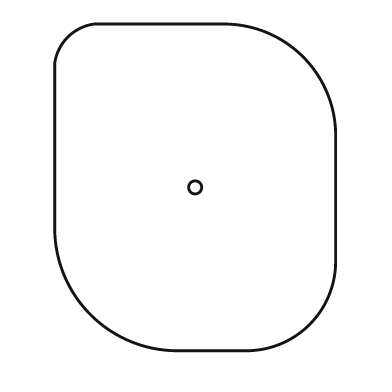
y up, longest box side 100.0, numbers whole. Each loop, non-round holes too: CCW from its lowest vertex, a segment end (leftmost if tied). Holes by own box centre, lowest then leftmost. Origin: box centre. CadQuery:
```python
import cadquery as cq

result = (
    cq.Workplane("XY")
    .moveTo(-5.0, -50.0)
    .lineTo(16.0, -50.0)
    .threePointArc((35.0, -42.0), (43.0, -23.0))
    .lineTo(43.0, 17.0)
    .threePointArc((33.0, 40.0), (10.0, 50.0))
    .lineTo(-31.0, 50.0)
    .threePointArc((-39.0, 46.0), (-43.0, 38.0))
    .lineTo(-43.0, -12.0)
    .threePointArc((-32.0, -39.0), (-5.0, -50.0))
    .close()
    .moveTo(0.0, 0.0)
    .circle(2.0)
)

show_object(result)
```